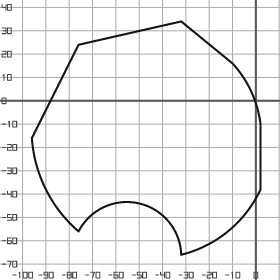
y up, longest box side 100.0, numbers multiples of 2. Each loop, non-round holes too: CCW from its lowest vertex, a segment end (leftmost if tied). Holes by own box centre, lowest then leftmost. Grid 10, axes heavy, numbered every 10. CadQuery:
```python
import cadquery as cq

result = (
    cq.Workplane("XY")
    .moveTo(-32.0, -66.0)
    .threePointArc((-12.0, -56.0), (2.0, -38.0))
    .lineTo(2.0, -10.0)
    .threePointArc((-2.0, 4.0), (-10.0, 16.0))
    .lineTo(-32.0, 34.0)
    .lineTo(-76.0, 24.0)
    .lineTo(-96.0, -16.0)
    .threePointArc((-90.0, -38.0), (-76.0, -56.0))
    .threePointArc((-50.0, -44.0), (-32.0, -66.0))
    .close()
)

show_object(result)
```